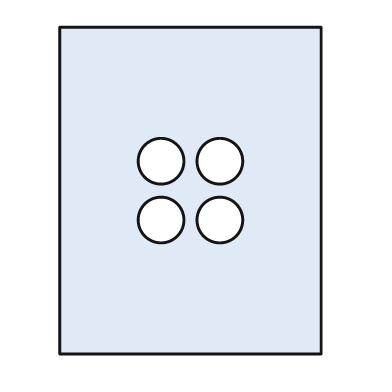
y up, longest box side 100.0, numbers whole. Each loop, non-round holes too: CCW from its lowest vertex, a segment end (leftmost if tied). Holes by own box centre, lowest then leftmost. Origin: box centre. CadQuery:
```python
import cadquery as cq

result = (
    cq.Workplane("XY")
    .moveTo(-40.0, -50.0)
    .lineTo(40.0, -50.0)
    .lineTo(40.0, 50.0)
    .lineTo(-40.0, 50.0)
    .close()
    .moveTo(-9.0, -9.0)
    .circle(7.0)
    .moveTo(9.0, -9.0)
    .circle(7.0)
    .moveTo(-9.0, 9.0)
    .circle(7.0)
    .moveTo(9.0, 9.0)
    .circle(7.0)
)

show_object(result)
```